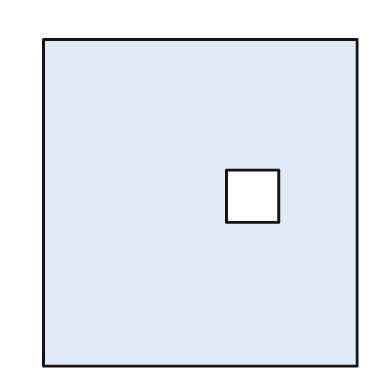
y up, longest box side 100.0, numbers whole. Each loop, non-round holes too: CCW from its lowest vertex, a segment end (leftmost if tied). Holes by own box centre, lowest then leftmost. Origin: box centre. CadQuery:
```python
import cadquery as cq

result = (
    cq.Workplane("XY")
    .moveTo(-48.0, -50.0)
    .lineTo(48.0, -50.0)
    .lineTo(48.0, 50.0)
    .lineTo(-48.0, 50.0)
    .close()
    .moveTo(8.0, -6.0)
    .lineTo(24.0, -6.0)
    .lineTo(24.0, 10.0)
    .lineTo(8.0, 10.0)
    .close()
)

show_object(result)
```